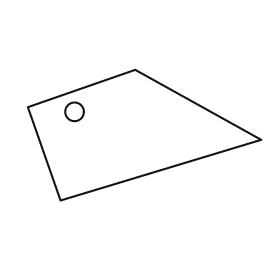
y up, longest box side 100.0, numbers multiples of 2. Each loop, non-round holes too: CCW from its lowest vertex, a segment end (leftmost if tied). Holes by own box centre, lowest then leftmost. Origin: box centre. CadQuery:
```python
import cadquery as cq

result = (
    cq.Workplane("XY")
    .moveTo(-36.0, -28.0)
    .lineTo(50.0, -2.0)
    .lineTo(-4.0, 28.0)
    .lineTo(-50.0, 12.0)
    .close()
    .moveTo(-30.0, 10.0)
    .circle(4.0)
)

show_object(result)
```